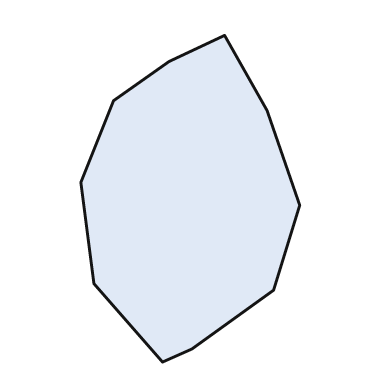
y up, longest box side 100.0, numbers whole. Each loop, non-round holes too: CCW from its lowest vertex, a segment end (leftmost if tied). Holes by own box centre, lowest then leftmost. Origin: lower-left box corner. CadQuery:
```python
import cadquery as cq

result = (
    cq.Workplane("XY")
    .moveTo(25.0, 0.0)
    .lineTo(34.0, 4.0)
    .lineTo(59.0, 22.0)
    .lineTo(67.0, 48.0)
    .lineTo(57.0, 77.0)
    .lineTo(44.0, 100.0)
    .lineTo(27.0, 92.0)
    .lineTo(10.0, 80.0)
    .lineTo(0.0, 55.0)
    .lineTo(4.0, 24.0)
    .close()
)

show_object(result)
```